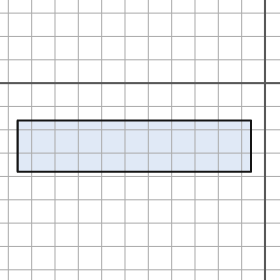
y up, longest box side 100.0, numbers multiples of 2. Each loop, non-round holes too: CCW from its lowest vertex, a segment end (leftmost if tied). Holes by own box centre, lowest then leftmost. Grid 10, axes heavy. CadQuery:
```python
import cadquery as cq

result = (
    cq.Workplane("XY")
    .moveTo(-106.0, -38.0)
    .lineTo(-6.0, -38.0)
    .lineTo(-6.0, -16.0)
    .lineTo(-106.0, -16.0)
    .close()
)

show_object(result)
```